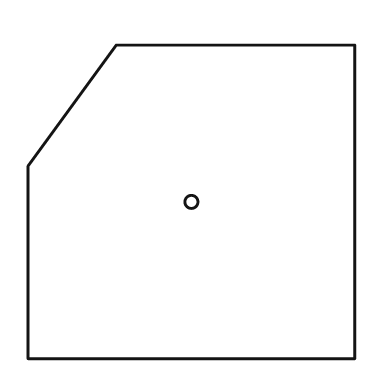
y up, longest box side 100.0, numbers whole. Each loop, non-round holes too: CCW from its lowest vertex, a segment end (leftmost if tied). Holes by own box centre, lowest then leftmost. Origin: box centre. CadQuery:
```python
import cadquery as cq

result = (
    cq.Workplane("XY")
    .moveTo(-50.0, -48.0)
    .lineTo(50.0, -48.0)
    .lineTo(50.0, 48.0)
    .lineTo(-23.0, 48.0)
    .lineTo(-50.0, 11.0)
    .close()
    .moveTo(0.0, 0.0)
    .circle(2.0)
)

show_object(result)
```